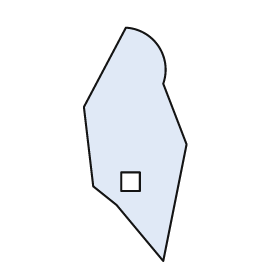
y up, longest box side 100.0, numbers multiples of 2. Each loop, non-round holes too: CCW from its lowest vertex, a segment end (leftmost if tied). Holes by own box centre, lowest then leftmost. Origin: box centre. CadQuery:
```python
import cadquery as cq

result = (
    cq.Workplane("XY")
    .moveTo(12.0, -50.0)
    .lineTo(22.0, 0.0)
    .lineTo(12.0, 26.0)
    .threePointArc((10.0, 42.0), (-4.0, 50.0))
    .lineTo(-22.0, 16.0)
    .lineTo(-18.0, -18.0)
    .lineTo(-8.0, -26.0)
    .close()
    .moveTo(-6.0, -20.0)
    .lineTo(2.0, -20.0)
    .lineTo(2.0, -12.0)
    .lineTo(-6.0, -12.0)
    .close()
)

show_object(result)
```